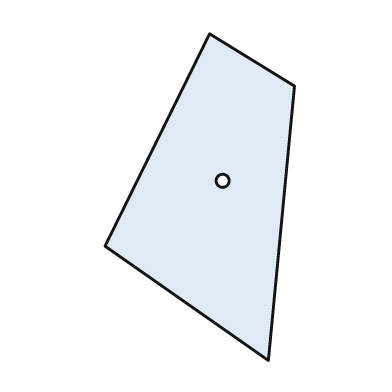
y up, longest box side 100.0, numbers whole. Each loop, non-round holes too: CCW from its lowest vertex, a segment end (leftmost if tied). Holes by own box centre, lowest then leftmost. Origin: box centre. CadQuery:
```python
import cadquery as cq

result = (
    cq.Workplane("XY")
    .moveTo(21.0, -50.0)
    .lineTo(29.0, 34.0)
    .lineTo(3.0, 50.0)
    .lineTo(-29.0, -15.0)
    .close()
    .moveTo(7.0, 5.0)
    .circle(2.0)
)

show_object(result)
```